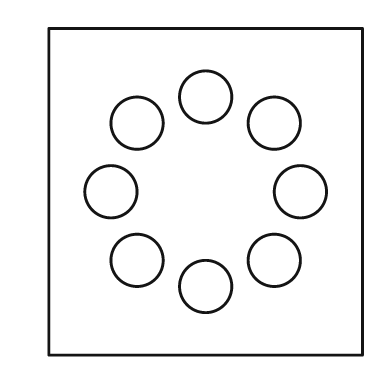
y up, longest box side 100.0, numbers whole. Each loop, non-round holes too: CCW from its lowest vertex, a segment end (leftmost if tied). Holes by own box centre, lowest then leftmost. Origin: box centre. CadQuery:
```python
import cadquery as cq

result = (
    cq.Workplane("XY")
    .moveTo(-48.0, -50.0)
    .lineTo(48.0, -50.0)
    .lineTo(48.0, 50.0)
    .lineTo(-48.0, 50.0)
    .close()
    .moveTo(0.0, -29.0)
    .circle(8.0)
    .moveTo(-21.0, -21.0)
    .circle(8.0)
    .moveTo(21.0, -21.0)
    .circle(8.0)
    .moveTo(-29.0, 0.0)
    .circle(8.0)
    .moveTo(29.0, 0.0)
    .circle(8.0)
    .moveTo(-21.0, 21.0)
    .circle(8.0)
    .moveTo(21.0, 21.0)
    .circle(8.0)
    .moveTo(0.0, 29.0)
    .circle(8.0)
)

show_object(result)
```